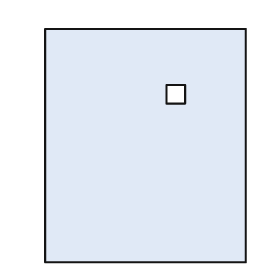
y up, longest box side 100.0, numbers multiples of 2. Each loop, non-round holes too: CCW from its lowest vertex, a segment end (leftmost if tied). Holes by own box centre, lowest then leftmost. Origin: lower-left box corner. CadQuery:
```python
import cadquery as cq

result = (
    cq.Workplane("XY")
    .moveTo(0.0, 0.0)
    .lineTo(86.0, 0.0)
    .lineTo(86.0, 100.0)
    .lineTo(0.0, 100.0)
    .close()
    .moveTo(52.0, 68.0)
    .lineTo(60.0, 68.0)
    .lineTo(60.0, 76.0)
    .lineTo(52.0, 76.0)
    .close()
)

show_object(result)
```